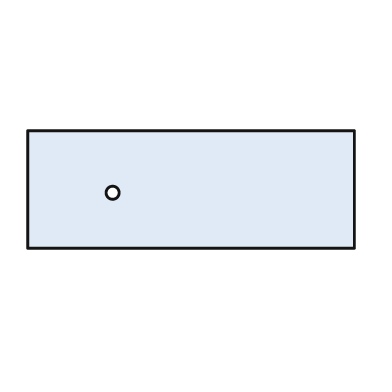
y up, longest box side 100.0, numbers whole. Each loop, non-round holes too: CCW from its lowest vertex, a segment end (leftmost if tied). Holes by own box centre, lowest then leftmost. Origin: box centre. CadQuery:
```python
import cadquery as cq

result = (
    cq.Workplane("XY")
    .moveTo(-50.0, -18.0)
    .lineTo(50.0, -18.0)
    .lineTo(50.0, 18.0)
    .lineTo(-50.0, 18.0)
    .close()
    .moveTo(-24.0, -1.0)
    .circle(2.0)
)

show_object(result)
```